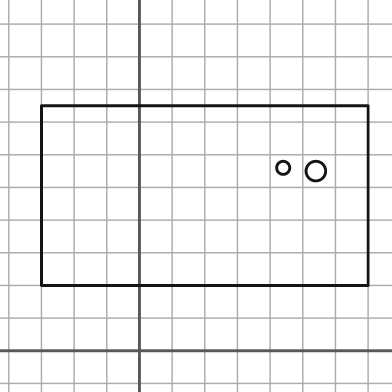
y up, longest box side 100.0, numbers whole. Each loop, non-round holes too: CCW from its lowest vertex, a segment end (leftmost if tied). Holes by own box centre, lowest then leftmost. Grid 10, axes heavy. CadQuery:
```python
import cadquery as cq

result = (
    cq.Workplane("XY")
    .moveTo(-30.0, 20.0)
    .lineTo(70.0, 20.0)
    .lineTo(70.0, 75.0)
    .lineTo(-30.0, 75.0)
    .close()
    .moveTo(54.0, 55.0)
    .circle(3.0)
    .moveTo(44.0, 56.0)
    .circle(2.0)
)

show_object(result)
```